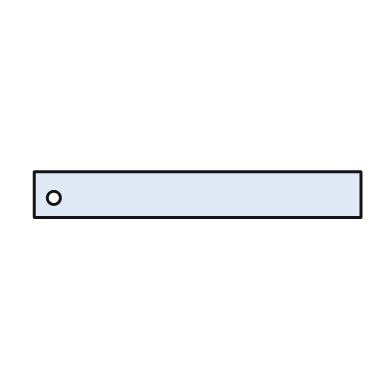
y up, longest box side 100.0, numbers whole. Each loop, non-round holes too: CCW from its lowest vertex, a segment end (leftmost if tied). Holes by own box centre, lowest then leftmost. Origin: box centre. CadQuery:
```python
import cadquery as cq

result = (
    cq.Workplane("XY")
    .moveTo(-50.0, -7.0)
    .lineTo(50.0, -7.0)
    .lineTo(50.0, 7.0)
    .lineTo(-50.0, 7.0)
    .close()
    .moveTo(-44.0, -1.0)
    .circle(2.0)
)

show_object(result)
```